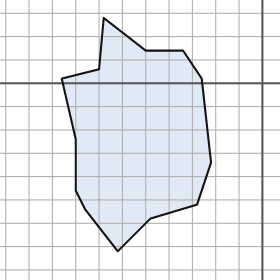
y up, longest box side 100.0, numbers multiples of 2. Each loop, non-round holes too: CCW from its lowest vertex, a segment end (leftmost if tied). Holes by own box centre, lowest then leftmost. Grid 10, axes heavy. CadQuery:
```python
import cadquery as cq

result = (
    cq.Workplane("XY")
    .moveTo(-62.0, -72.0)
    .lineTo(-48.0, -58.0)
    .lineTo(-28.0, -52.0)
    .lineTo(-22.0, -34.0)
    .lineTo(-26.0, 2.0)
    .lineTo(-34.0, 14.0)
    .lineTo(-50.0, 14.0)
    .lineTo(-68.0, 28.0)
    .lineTo(-70.0, 6.0)
    .lineTo(-86.0, 2.0)
    .lineTo(-80.0, -24.0)
    .lineTo(-80.0, -46.0)
    .lineTo(-76.0, -54.0)
    .close()
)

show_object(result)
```